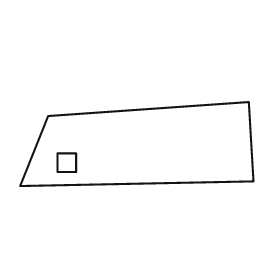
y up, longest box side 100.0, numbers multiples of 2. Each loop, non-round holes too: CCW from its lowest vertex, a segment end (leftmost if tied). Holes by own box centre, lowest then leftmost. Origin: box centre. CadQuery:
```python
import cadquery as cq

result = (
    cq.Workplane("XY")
    .moveTo(-50.0, -18.0)
    .lineTo(50.0, -16.0)
    .lineTo(48.0, 18.0)
    .lineTo(-38.0, 12.0)
    .close()
    .moveTo(-34.0, -12.0)
    .lineTo(-26.0, -12.0)
    .lineTo(-26.0, -4.0)
    .lineTo(-34.0, -4.0)
    .close()
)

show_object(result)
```